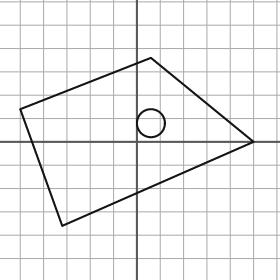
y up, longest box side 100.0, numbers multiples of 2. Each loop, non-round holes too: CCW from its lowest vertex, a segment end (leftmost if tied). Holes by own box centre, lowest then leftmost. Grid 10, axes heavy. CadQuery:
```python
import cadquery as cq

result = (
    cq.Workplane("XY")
    .moveTo(-32.0, -36.0)
    .lineTo(50.0, 0.0)
    .lineTo(6.0, 36.0)
    .lineTo(-50.0, 14.0)
    .close()
    .moveTo(6.0, 8.0)
    .circle(6.0)
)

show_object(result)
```